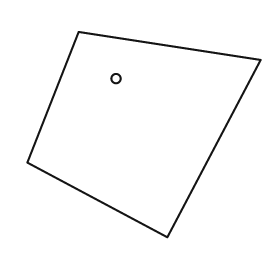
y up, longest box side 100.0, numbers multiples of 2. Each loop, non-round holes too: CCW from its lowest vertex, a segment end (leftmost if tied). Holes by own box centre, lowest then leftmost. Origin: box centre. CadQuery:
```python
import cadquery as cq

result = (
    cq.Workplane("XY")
    .moveTo(10.0, -44.0)
    .lineTo(50.0, 32.0)
    .lineTo(-28.0, 44.0)
    .lineTo(-50.0, -12.0)
    .close()
    .moveTo(-12.0, 24.0)
    .circle(2.0)
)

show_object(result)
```